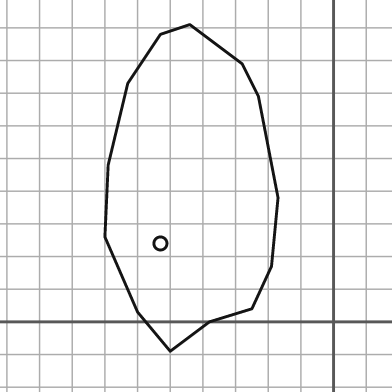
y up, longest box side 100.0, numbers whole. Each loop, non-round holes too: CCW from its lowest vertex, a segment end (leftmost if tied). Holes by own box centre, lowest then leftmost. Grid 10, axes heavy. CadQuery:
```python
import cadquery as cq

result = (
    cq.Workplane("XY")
    .moveTo(-50.0, -9.0)
    .lineTo(-38.0, 0.0)
    .lineTo(-25.0, 4.0)
    .lineTo(-19.0, 17.0)
    .lineTo(-17.0, 38.0)
    .lineTo(-23.0, 69.0)
    .lineTo(-28.0, 79.0)
    .lineTo(-44.0, 91.0)
    .lineTo(-53.0, 88.0)
    .lineTo(-63.0, 73.0)
    .lineTo(-69.0, 48.0)
    .lineTo(-70.0, 26.0)
    .lineTo(-60.0, 3.0)
    .close()
    .moveTo(-53.0, 24.0)
    .circle(2.0)
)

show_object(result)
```